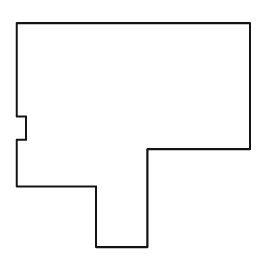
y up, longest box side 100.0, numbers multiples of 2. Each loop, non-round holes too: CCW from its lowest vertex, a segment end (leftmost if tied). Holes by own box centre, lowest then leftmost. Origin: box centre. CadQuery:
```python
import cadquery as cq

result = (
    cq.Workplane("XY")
    .moveTo(-16.0, -48.0)
    .lineTo(6.0, -48.0)
    .lineTo(6.0, -6.0)
    .lineTo(50.0, -6.0)
    .lineTo(50.0, 48.0)
    .lineTo(-50.0, 48.0)
    .lineTo(-50.0, 8.0)
    .lineTo(-46.0, 8.0)
    .lineTo(-46.0, -2.0)
    .lineTo(-50.0, -2.0)
    .lineTo(-50.0, -22.0)
    .lineTo(-16.0, -22.0)
    .close()
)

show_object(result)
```